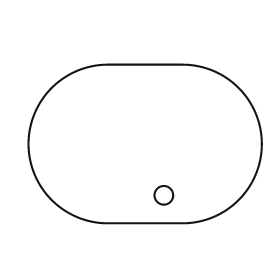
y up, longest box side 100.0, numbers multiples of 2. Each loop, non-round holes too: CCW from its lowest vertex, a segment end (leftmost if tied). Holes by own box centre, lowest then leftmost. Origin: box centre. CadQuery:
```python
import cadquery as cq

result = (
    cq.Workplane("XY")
    .moveTo(-16.0, -34.0)
    .lineTo(16.0, -34.0)
    .threePointArc((50.0, 0.0), (16.0, 34.0))
    .lineTo(-16.0, 34.0)
    .threePointArc((-50.0, 0.0), (-16.0, -34.0))
    .close()
    .moveTo(8.0, -22.0)
    .circle(4.0)
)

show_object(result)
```